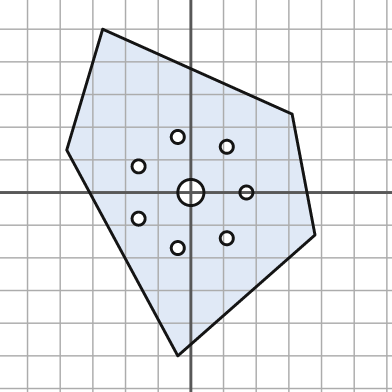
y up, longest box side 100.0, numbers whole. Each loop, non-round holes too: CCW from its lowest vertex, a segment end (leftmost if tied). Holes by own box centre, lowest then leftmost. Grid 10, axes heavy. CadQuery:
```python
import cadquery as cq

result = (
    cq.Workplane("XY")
    .moveTo(-4.0, -50.0)
    .lineTo(38.0, -13.0)
    .lineTo(31.0, 24.0)
    .lineTo(-27.0, 50.0)
    .lineTo(-38.0, 13.0)
    .close()
    .moveTo(-4.0, -17.0)
    .circle(2.0)
    .moveTo(11.0, -14.0)
    .circle(2.0)
    .moveTo(-16.0, -8.0)
    .circle(2.0)
    .moveTo(0.0, 0.0)
    .circle(4.0)
    .moveTo(17.0, 0.0)
    .circle(2.0)
    .moveTo(-16.0, 8.0)
    .circle(2.0)
    .moveTo(11.0, 14.0)
    .circle(2.0)
    .moveTo(-4.0, 17.0)
    .circle(2.0)
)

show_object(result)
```